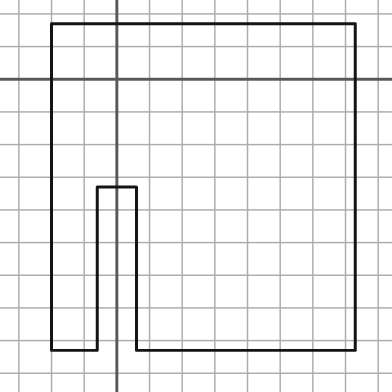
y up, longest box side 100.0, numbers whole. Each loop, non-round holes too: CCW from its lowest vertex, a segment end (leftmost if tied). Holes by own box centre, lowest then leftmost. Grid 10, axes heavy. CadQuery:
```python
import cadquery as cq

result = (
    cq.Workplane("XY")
    .moveTo(-20.0, -83.0)
    .lineTo(-6.0, -83.0)
    .lineTo(-6.0, -33.0)
    .lineTo(6.0, -33.0)
    .lineTo(6.0, -83.0)
    .lineTo(73.0, -83.0)
    .lineTo(73.0, 17.0)
    .lineTo(-20.0, 17.0)
    .close()
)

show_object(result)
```